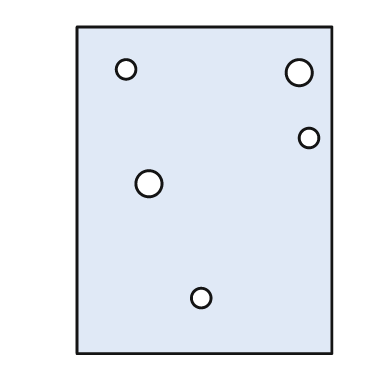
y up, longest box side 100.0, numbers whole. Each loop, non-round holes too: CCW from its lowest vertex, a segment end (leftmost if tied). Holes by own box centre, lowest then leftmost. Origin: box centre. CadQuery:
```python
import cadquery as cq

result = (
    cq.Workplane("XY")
    .moveTo(-39.0, -50.0)
    .lineTo(39.0, -50.0)
    .lineTo(39.0, 50.0)
    .lineTo(-39.0, 50.0)
    .close()
    .moveTo(-1.0, -33.0)
    .circle(3.0)
    .moveTo(-17.0, 2.0)
    .circle(4.0)
    .moveTo(32.0, 16.0)
    .circle(3.0)
    .moveTo(29.0, 36.0)
    .circle(4.0)
    .moveTo(-24.0, 37.0)
    .circle(3.0)
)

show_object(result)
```